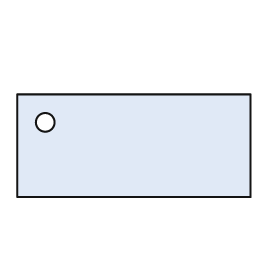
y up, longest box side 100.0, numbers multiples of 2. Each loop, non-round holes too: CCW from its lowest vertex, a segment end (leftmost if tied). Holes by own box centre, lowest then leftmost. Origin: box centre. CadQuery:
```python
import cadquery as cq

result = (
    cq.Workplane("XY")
    .moveTo(-50.0, -22.0)
    .lineTo(50.0, -22.0)
    .lineTo(50.0, 22.0)
    .lineTo(-50.0, 22.0)
    .close()
    .moveTo(-38.0, 10.0)
    .circle(4.0)
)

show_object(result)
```